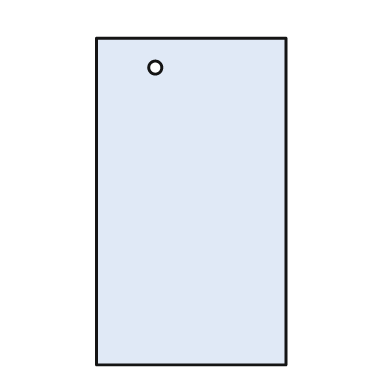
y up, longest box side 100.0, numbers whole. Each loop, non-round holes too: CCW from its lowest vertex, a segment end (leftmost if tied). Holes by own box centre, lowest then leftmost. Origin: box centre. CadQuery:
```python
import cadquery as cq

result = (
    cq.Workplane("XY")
    .moveTo(-29.0, -50.0)
    .lineTo(29.0, -50.0)
    .lineTo(29.0, 50.0)
    .lineTo(-29.0, 50.0)
    .close()
    .moveTo(-11.0, 41.0)
    .circle(2.0)
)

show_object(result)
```